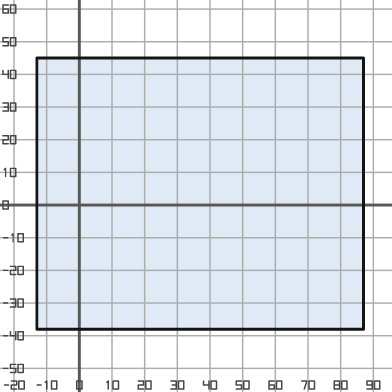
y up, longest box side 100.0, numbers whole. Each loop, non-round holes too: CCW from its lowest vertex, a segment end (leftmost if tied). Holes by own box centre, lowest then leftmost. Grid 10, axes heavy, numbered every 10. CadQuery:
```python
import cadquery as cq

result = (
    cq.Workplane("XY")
    .moveTo(-13.0, -38.0)
    .lineTo(87.0, -38.0)
    .lineTo(87.0, 45.0)
    .lineTo(-13.0, 45.0)
    .close()
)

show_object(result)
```